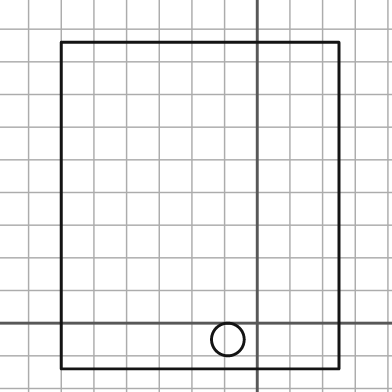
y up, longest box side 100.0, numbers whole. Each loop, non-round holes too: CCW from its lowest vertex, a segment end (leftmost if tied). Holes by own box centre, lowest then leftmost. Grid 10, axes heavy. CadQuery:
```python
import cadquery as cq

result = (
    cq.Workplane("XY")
    .moveTo(-60.0, -14.0)
    .lineTo(25.0, -14.0)
    .lineTo(25.0, 86.0)
    .lineTo(-60.0, 86.0)
    .close()
    .moveTo(-9.0, -5.0)
    .circle(5.0)
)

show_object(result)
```